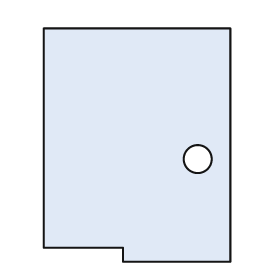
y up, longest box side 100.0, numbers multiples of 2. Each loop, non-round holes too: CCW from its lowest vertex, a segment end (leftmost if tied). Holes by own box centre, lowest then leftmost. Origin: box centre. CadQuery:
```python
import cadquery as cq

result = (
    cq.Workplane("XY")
    .moveTo(-6.0, -50.0)
    .lineTo(40.0, -50.0)
    .lineTo(40.0, 50.0)
    .lineTo(-40.0, 50.0)
    .lineTo(-40.0, -44.0)
    .lineTo(-6.0, -44.0)
    .close()
    .moveTo(26.0, -6.0)
    .circle(6.0)
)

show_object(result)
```